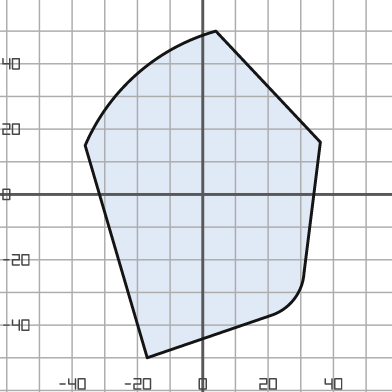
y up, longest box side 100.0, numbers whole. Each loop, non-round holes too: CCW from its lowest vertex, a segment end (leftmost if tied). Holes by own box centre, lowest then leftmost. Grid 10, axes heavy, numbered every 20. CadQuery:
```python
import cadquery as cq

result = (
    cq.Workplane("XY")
    .moveTo(-17.0, -50.0)
    .lineTo(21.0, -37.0)
    .threePointArc((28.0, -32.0), (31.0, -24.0))
    .lineTo(36.0, 16.0)
    .lineTo(4.0, 50.0)
    .threePointArc((-20.0, 37.0), (-36.0, 15.0))
    .close()
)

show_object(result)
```